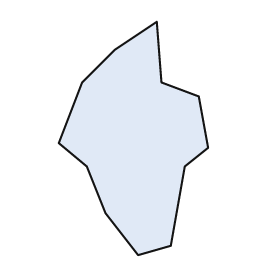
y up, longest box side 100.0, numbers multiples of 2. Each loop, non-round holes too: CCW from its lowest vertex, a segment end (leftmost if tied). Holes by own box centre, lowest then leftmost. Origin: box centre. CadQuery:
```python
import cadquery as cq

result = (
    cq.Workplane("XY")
    .moveTo(2.0, -50.0)
    .lineTo(16.0, -46.0)
    .lineTo(22.0, -12.0)
    .lineTo(32.0, -4.0)
    .lineTo(28.0, 18.0)
    .lineTo(12.0, 24.0)
    .lineTo(10.0, 50.0)
    .lineTo(-8.0, 38.0)
    .lineTo(-22.0, 24.0)
    .lineTo(-32.0, -2.0)
    .lineTo(-20.0, -12.0)
    .lineTo(-12.0, -32.0)
    .close()
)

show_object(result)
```